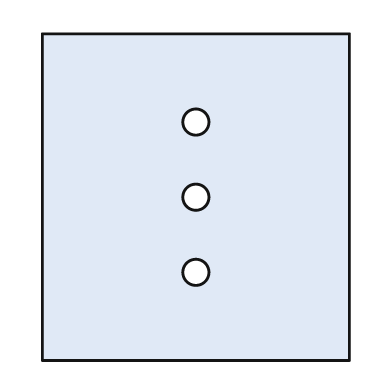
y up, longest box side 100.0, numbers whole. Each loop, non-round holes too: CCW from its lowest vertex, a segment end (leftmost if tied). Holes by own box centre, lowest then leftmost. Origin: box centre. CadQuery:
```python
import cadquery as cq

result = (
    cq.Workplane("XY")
    .moveTo(-47.0, -50.0)
    .lineTo(47.0, -50.0)
    .lineTo(47.0, 50.0)
    .lineTo(-47.0, 50.0)
    .close()
    .moveTo(0.0, -23.0)
    .circle(4.0)
    .moveTo(0.0, 0.0)
    .circle(4.0)
    .moveTo(0.0, 23.0)
    .circle(4.0)
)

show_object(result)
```